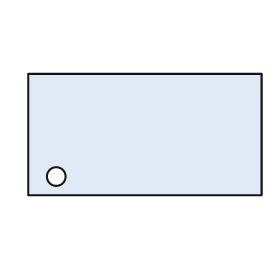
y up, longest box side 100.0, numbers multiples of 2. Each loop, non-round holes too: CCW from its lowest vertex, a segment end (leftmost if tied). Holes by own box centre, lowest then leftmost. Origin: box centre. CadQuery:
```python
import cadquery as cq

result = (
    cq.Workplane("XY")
    .moveTo(-50.0, -26.0)
    .lineTo(50.0, -26.0)
    .lineTo(50.0, 26.0)
    .lineTo(-50.0, 26.0)
    .close()
    .moveTo(-38.0, -18.0)
    .circle(4.0)
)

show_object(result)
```